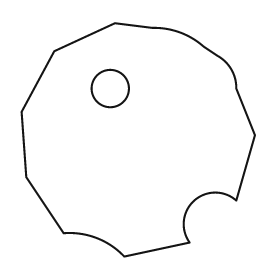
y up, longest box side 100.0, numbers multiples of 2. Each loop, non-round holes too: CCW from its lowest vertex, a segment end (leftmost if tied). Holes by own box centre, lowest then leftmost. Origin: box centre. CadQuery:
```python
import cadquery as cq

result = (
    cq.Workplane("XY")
    .moveTo(-6.0, -50.0)
    .lineTo(22.0, -44.0)
    .threePointArc((24.0, -26.0), (42.0, -26.0))
    .lineTo(50.0, 2.0)
    .lineTo(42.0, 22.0)
    .threePointArc((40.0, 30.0), (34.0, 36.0))
    .lineTo(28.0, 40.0)
    .threePointArc((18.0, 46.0), (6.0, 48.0))
    .lineTo(-10.0, 50.0)
    .lineTo(-36.0, 38.0)
    .lineTo(-50.0, 12.0)
    .lineTo(-48.0, -16.0)
    .lineTo(-32.0, -40.0)
    .threePointArc((-18.0, -42.0), (-6.0, -50.0))
    .close()
    .moveTo(-12.0, 22.0)
    .circle(8.0)
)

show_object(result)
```